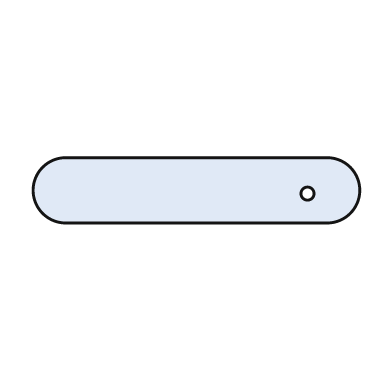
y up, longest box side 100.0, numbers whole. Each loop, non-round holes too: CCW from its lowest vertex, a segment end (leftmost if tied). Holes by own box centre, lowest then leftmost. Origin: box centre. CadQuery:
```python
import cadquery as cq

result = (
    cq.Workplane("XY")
    .moveTo(-40.0, -10.0)
    .lineTo(40.0, -10.0)
    .threePointArc((50.0, 0.0), (40.0, 10.0))
    .lineTo(-40.0, 10.0)
    .threePointArc((-50.0, 0.0), (-40.0, -10.0))
    .close()
    .moveTo(34.0, -1.0)
    .circle(2.0)
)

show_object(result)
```